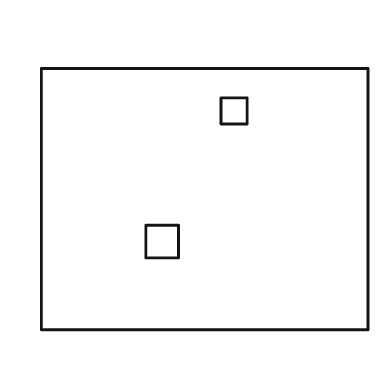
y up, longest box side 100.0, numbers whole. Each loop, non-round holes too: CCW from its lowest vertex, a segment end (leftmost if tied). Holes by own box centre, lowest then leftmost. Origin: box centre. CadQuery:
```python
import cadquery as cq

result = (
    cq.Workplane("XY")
    .moveTo(-50.0, -40.0)
    .lineTo(50.0, -40.0)
    .lineTo(50.0, 40.0)
    .lineTo(-50.0, 40.0)
    .close()
    .moveTo(-18.0, -18.0)
    .lineTo(-8.0, -18.0)
    .lineTo(-8.0, -8.0)
    .lineTo(-18.0, -8.0)
    .close()
    .moveTo(5.0, 23.0)
    .lineTo(13.0, 23.0)
    .lineTo(13.0, 31.0)
    .lineTo(5.0, 31.0)
    .close()
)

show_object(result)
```